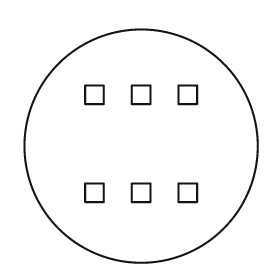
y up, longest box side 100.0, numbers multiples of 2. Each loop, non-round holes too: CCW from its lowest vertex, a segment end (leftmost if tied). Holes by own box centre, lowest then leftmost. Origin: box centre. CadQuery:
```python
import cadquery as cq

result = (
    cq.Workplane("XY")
    .moveTo(0.0, 0.0)
    .circle(50.0)
    .moveTo(-24.0, -24.0)
    .lineTo(-16.0, -24.0)
    .lineTo(-16.0, -16.0)
    .lineTo(-24.0, -16.0)
    .close()
    .moveTo(-4.0, -24.0)
    .lineTo(4.0, -24.0)
    .lineTo(4.0, -16.0)
    .lineTo(-4.0, -16.0)
    .close()
    .moveTo(16.0, -24.0)
    .lineTo(24.0, -24.0)
    .lineTo(24.0, -16.0)
    .lineTo(16.0, -16.0)
    .close()
    .moveTo(-24.0, 18.0)
    .lineTo(-16.0, 18.0)
    .lineTo(-16.0, 26.0)
    .lineTo(-24.0, 26.0)
    .close()
    .moveTo(-4.0, 18.0)
    .lineTo(4.0, 18.0)
    .lineTo(4.0, 26.0)
    .lineTo(-4.0, 26.0)
    .close()
    .moveTo(16.0, 18.0)
    .lineTo(24.0, 18.0)
    .lineTo(24.0, 26.0)
    .lineTo(16.0, 26.0)
    .close()
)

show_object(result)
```